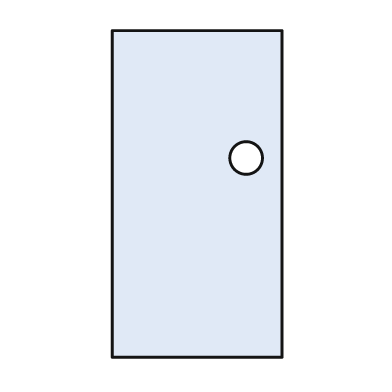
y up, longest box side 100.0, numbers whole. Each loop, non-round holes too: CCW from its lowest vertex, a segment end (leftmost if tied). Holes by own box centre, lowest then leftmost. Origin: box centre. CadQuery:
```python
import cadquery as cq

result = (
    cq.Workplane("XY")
    .moveTo(-26.0, -50.0)
    .lineTo(26.0, -50.0)
    .lineTo(26.0, 50.0)
    .lineTo(-26.0, 50.0)
    .close()
    .moveTo(15.0, 11.0)
    .circle(5.0)
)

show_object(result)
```